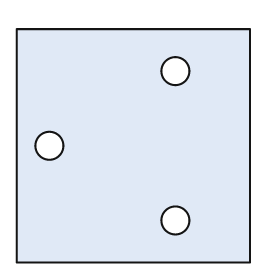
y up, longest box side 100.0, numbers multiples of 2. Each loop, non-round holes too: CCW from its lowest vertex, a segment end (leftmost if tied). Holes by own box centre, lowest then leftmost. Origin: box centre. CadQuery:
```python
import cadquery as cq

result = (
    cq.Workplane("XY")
    .moveTo(-50.0, -50.0)
    .lineTo(50.0, -50.0)
    .lineTo(50.0, 50.0)
    .lineTo(-50.0, 50.0)
    .close()
    .moveTo(18.0, -32.0)
    .circle(6.0)
    .moveTo(-36.0, 0.0)
    .circle(6.0)
    .moveTo(18.0, 32.0)
    .circle(6.0)
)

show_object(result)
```